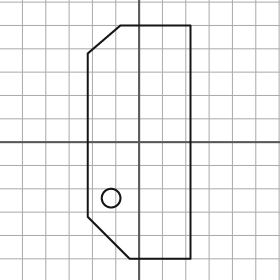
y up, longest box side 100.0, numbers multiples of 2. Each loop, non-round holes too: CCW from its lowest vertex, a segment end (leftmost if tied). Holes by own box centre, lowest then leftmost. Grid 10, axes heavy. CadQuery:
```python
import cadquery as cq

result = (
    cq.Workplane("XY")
    .moveTo(-4.0, -50.0)
    .lineTo(22.0, -50.0)
    .lineTo(22.0, 50.0)
    .lineTo(-8.0, 50.0)
    .lineTo(-22.0, 38.0)
    .lineTo(-22.0, -32.0)
    .close()
    .moveTo(-12.0, -24.0)
    .circle(4.0)
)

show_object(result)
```